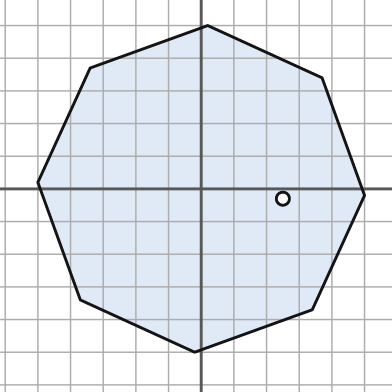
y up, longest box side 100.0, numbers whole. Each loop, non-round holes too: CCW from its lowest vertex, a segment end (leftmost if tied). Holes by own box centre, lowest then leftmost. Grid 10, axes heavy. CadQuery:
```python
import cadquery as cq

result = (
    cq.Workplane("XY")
    .moveTo(-2.0, -50.0)
    .lineTo(34.0, -37.0)
    .lineTo(50.0, -2.0)
    .lineTo(37.0, 34.0)
    .lineTo(2.0, 50.0)
    .lineTo(-34.0, 37.0)
    .lineTo(-50.0, 2.0)
    .lineTo(-37.0, -34.0)
    .close()
    .moveTo(25.0, -3.0)
    .circle(2.0)
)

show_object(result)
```